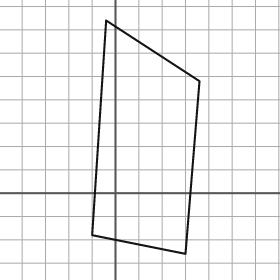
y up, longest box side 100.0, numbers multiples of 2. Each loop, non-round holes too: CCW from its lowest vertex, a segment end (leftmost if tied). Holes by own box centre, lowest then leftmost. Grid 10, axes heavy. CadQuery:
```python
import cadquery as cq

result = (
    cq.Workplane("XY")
    .moveTo(30.0, -26.0)
    .lineTo(36.0, 48.0)
    .lineTo(-4.0, 74.0)
    .lineTo(-10.0, -18.0)
    .close()
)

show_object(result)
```